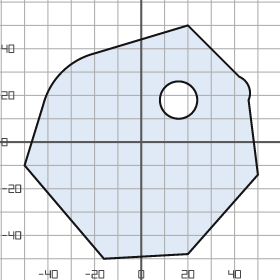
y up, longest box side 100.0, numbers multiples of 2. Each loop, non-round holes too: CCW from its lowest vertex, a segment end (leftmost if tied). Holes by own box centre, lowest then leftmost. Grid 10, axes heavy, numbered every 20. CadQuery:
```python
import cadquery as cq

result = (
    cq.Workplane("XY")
    .moveTo(-16.0, -50.0)
    .lineTo(20.0, -48.0)
    .lineTo(50.0, -14.0)
    .lineTo(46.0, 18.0)
    .threePointArc((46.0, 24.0), (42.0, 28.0))
    .lineTo(20.0, 50.0)
    .lineTo(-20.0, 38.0)
    .threePointArc((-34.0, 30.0), (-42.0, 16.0))
    .lineTo(-50.0, -10.0)
    .close()
    .moveTo(16.0, 18.0)
    .circle(8.0)
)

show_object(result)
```